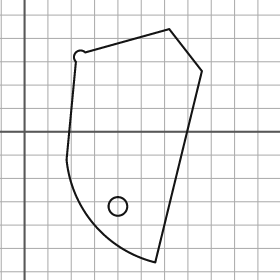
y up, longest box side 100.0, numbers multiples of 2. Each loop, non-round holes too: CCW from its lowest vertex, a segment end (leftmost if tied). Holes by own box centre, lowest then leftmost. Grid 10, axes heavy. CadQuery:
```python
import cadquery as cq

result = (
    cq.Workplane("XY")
    .moveTo(56.0, -56.0)
    .lineTo(76.0, 26.0)
    .lineTo(62.0, 44.0)
    .lineTo(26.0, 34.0)
    .threePointArc((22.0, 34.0), (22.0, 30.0))
    .lineTo(18.0, -12.0)
    .threePointArc((30.0, -40.0), (56.0, -56.0))
    .close()
    .moveTo(40.0, -32.0)
    .circle(4.0)
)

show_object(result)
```